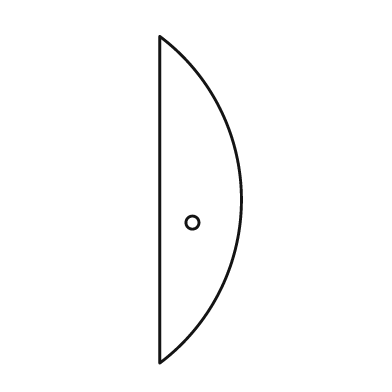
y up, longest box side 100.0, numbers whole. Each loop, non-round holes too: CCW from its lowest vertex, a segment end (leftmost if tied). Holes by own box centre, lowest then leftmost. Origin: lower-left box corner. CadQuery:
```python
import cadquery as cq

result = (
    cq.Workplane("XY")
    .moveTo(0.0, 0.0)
    .threePointArc((25.0, 50.0), (0.0, 100.0))
    .close()
    .moveTo(10.0, 43.0)
    .circle(2.0)
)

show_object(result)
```